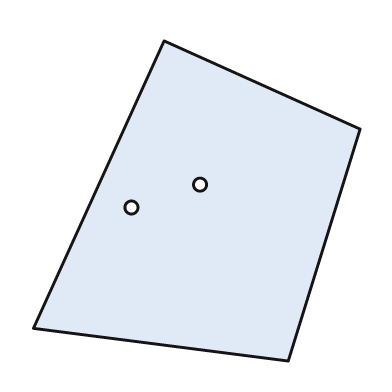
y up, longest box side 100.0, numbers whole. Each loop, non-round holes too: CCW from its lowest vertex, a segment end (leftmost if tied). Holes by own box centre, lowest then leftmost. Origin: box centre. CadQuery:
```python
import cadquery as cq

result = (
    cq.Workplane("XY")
    .moveTo(28.0, -49.0)
    .lineTo(50.0, 22.0)
    .lineTo(-10.0, 49.0)
    .lineTo(-50.0, -39.0)
    .close()
    .moveTo(-20.0, -2.0)
    .circle(2.0)
    .moveTo(1.0, 5.0)
    .circle(2.0)
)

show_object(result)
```